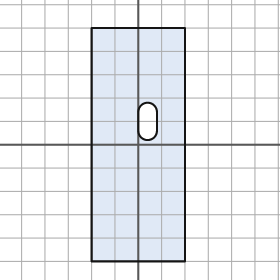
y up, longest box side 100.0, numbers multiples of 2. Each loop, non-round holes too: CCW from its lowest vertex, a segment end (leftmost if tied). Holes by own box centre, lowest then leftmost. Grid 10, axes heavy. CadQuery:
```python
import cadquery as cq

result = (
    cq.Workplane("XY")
    .moveTo(-20.0, -50.0)
    .lineTo(20.0, -50.0)
    .lineTo(20.0, 50.0)
    .lineTo(-20.0, 50.0)
    .close()
    .moveTo(0.0, 6.0)
    .threePointArc((4.0, 2.0), (8.0, 6.0))
    .lineTo(8.0, 14.0)
    .threePointArc((4.0, 18.0), (0.0, 14.0))
    .close()
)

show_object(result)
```